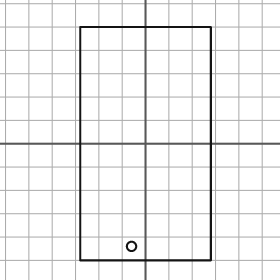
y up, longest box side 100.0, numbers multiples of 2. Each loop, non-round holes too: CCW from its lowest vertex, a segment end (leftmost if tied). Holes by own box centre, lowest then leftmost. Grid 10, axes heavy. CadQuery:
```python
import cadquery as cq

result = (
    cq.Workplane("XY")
    .moveTo(-28.0, -50.0)
    .lineTo(28.0, -50.0)
    .lineTo(28.0, 50.0)
    .lineTo(-28.0, 50.0)
    .close()
    .moveTo(-6.0, -44.0)
    .circle(2.0)
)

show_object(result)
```